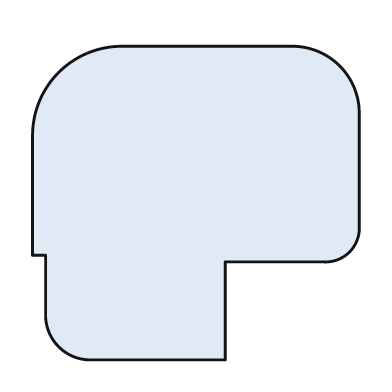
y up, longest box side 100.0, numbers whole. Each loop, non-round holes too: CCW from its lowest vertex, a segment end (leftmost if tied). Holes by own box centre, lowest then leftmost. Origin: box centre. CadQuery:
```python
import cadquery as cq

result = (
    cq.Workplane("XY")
    .moveTo(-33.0, -48.0)
    .lineTo(9.0, -48.0)
    .lineTo(9.0, -18.0)
    .lineTo(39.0, -18.0)
    .threePointArc((47.0, -15.0), (50.0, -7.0))
    .lineTo(50.0, 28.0)
    .threePointArc((44.0, 42.0), (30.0, 48.0))
    .lineTo(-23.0, 48.0)
    .threePointArc((-42.0, 40.0), (-50.0, 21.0))
    .lineTo(-50.0, -16.0)
    .lineTo(-46.0, -16.0)
    .lineTo(-46.0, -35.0)
    .threePointArc((-42.0, -44.0), (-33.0, -48.0))
    .close()
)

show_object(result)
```